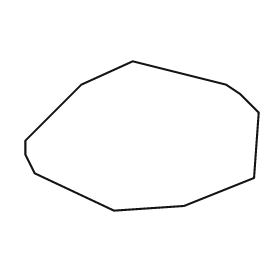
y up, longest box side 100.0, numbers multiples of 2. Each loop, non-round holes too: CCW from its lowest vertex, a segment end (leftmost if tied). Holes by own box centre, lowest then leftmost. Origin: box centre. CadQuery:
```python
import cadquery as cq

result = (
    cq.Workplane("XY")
    .moveTo(-12.0, -32.0)
    .lineTo(18.0, -30.0)
    .lineTo(48.0, -18.0)
    .lineTo(50.0, 10.0)
    .lineTo(42.0, 18.0)
    .lineTo(36.0, 22.0)
    .lineTo(-4.0, 32.0)
    .lineTo(-26.0, 22.0)
    .lineTo(-50.0, -2.0)
    .lineTo(-50.0, -8.0)
    .lineTo(-46.0, -16.0)
    .close()
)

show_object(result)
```